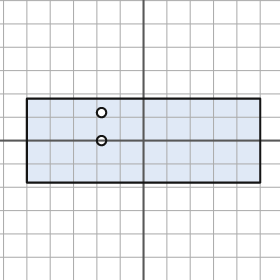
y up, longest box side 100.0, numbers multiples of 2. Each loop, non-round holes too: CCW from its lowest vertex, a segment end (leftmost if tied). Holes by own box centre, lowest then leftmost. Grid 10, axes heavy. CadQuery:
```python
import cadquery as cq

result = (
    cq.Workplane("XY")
    .moveTo(-50.0, -18.0)
    .lineTo(50.0, -18.0)
    .lineTo(50.0, 18.0)
    .lineTo(-50.0, 18.0)
    .close()
    .moveTo(-18.0, 0.0)
    .circle(2.0)
    .moveTo(-18.0, 12.0)
    .circle(2.0)
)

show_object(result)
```